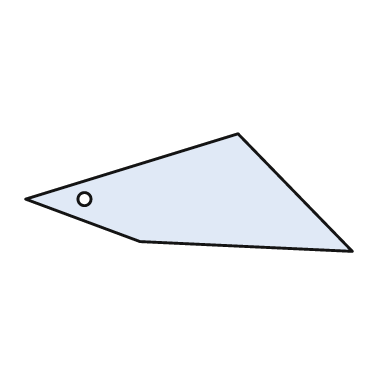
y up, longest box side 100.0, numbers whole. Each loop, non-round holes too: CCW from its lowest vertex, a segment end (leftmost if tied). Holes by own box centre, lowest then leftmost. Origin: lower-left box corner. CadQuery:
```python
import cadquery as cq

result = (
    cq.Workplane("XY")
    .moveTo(100.0, 0.0)
    .lineTo(65.0, 36.0)
    .lineTo(0.0, 16.0)
    .lineTo(35.0, 3.0)
    .close()
    .moveTo(18.0, 16.0)
    .circle(2.0)
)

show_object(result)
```